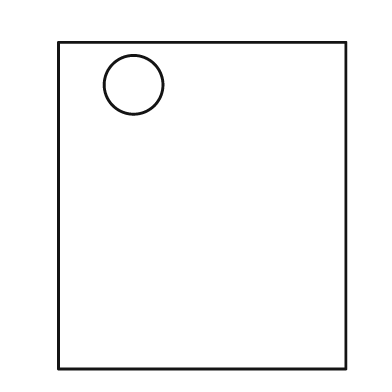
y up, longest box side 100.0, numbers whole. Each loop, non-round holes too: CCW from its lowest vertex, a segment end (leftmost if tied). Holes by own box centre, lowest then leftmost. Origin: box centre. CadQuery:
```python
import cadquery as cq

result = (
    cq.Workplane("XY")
    .moveTo(-44.0, -50.0)
    .lineTo(44.0, -50.0)
    .lineTo(44.0, 50.0)
    .lineTo(-44.0, 50.0)
    .close()
    .moveTo(-21.0, 37.0)
    .circle(9.0)
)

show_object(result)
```